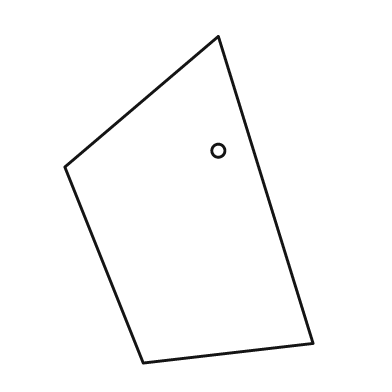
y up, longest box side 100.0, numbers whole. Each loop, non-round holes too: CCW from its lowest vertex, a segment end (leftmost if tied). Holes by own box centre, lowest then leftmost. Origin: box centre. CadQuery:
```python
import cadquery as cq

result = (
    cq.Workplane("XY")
    .moveTo(-14.0, -50.0)
    .lineTo(38.0, -44.0)
    .lineTo(9.0, 50.0)
    .lineTo(-38.0, 10.0)
    .close()
    .moveTo(9.0, 15.0)
    .circle(2.0)
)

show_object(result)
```